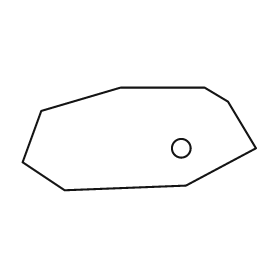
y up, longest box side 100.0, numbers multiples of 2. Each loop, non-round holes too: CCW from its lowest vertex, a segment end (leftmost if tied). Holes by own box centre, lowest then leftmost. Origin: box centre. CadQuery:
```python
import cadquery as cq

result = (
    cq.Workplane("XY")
    .moveTo(-32.0, -22.0)
    .lineTo(20.0, -20.0)
    .lineTo(50.0, -4.0)
    .lineTo(38.0, 16.0)
    .lineTo(28.0, 22.0)
    .lineTo(-8.0, 22.0)
    .lineTo(-42.0, 12.0)
    .lineTo(-50.0, -10.0)
    .close()
    .moveTo(18.0, -4.0)
    .circle(4.0)
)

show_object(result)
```